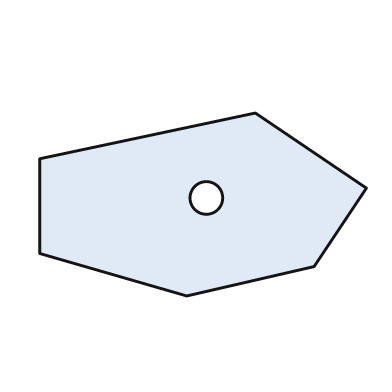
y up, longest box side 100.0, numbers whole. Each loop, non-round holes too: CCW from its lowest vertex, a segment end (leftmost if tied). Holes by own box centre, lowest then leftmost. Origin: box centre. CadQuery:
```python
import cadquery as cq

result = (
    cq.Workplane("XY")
    .moveTo(-5.0, -28.0)
    .lineTo(34.0, -19.0)
    .lineTo(50.0, 5.0)
    .lineTo(16.0, 28.0)
    .lineTo(-50.0, 14.0)
    .lineTo(-50.0, -15.0)
    .close()
    .moveTo(1.0, 2.0)
    .circle(5.0)
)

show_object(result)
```